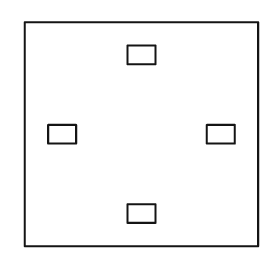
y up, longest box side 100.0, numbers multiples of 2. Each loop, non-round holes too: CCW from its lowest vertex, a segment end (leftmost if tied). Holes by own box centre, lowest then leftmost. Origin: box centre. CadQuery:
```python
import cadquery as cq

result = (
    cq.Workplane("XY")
    .moveTo(-50.0, -48.0)
    .lineTo(50.0, -48.0)
    .lineTo(50.0, 48.0)
    .lineTo(-50.0, 48.0)
    .close()
    .moveTo(-6.0, -38.0)
    .lineTo(6.0, -38.0)
    .lineTo(6.0, -30.0)
    .lineTo(-6.0, -30.0)
    .close()
    .moveTo(-40.0, -4.0)
    .lineTo(-28.0, -4.0)
    .lineTo(-28.0, 4.0)
    .lineTo(-40.0, 4.0)
    .close()
    .moveTo(28.0, -4.0)
    .lineTo(40.0, -4.0)
    .lineTo(40.0, 4.0)
    .lineTo(28.0, 4.0)
    .close()
    .moveTo(-6.0, 30.0)
    .lineTo(6.0, 30.0)
    .lineTo(6.0, 38.0)
    .lineTo(-6.0, 38.0)
    .close()
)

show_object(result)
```